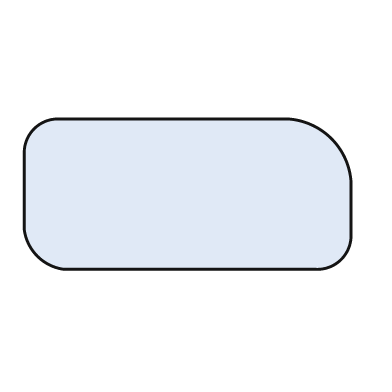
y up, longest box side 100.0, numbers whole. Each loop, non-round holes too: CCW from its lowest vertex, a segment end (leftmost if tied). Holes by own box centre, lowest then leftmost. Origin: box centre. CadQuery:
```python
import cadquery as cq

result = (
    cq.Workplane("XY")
    .moveTo(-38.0, -23.0)
    .lineTo(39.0, -23.0)
    .threePointArc((47.0, -20.0), (50.0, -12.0))
    .lineTo(50.0, 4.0)
    .threePointArc((44.0, 17.0), (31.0, 23.0))
    .lineTo(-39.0, 23.0)
    .threePointArc((-47.0, 20.0), (-50.0, 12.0))
    .lineTo(-50.0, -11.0)
    .threePointArc((-46.0, -19.0), (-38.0, -23.0))
    .close()
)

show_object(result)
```